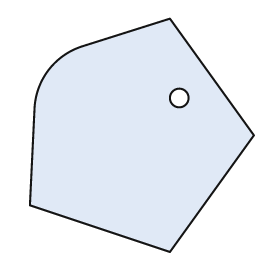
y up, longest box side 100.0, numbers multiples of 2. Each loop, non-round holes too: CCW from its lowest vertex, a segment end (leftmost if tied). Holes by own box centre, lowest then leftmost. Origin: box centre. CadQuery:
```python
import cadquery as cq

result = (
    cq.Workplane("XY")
    .moveTo(12.0, -50.0)
    .lineTo(48.0, 0.0)
    .lineTo(12.0, 50.0)
    .lineTo(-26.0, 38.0)
    .threePointArc((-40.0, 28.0), (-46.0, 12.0))
    .lineTo(-48.0, -30.0)
    .close()
    .moveTo(16.0, 16.0)
    .circle(4.0)
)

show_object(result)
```